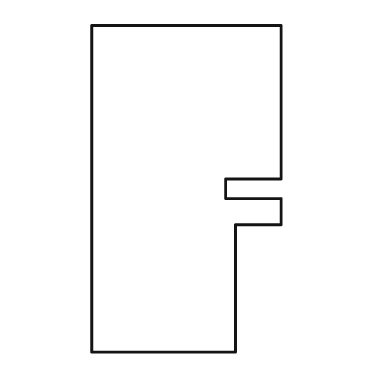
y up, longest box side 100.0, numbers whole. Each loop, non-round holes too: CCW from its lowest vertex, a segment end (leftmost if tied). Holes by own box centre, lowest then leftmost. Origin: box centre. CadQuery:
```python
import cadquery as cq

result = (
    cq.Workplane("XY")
    .moveTo(-29.0, -50.0)
    .lineTo(15.0, -50.0)
    .lineTo(15.0, -11.0)
    .lineTo(29.0, -11.0)
    .lineTo(29.0, -3.0)
    .lineTo(12.0, -3.0)
    .lineTo(12.0, 3.0)
    .lineTo(29.0, 3.0)
    .lineTo(29.0, 50.0)
    .lineTo(-29.0, 50.0)
    .close()
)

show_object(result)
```